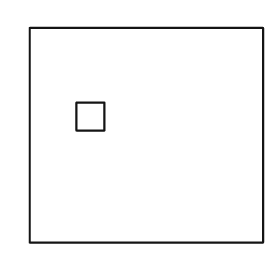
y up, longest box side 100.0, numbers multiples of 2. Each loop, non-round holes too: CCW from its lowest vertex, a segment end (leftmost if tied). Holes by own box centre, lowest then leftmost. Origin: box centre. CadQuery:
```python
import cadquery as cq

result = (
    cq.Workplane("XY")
    .moveTo(-50.0, -46.0)
    .lineTo(50.0, -46.0)
    .lineTo(50.0, 46.0)
    .lineTo(-50.0, 46.0)
    .close()
    .moveTo(-30.0, 2.0)
    .lineTo(-18.0, 2.0)
    .lineTo(-18.0, 14.0)
    .lineTo(-30.0, 14.0)
    .close()
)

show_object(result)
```